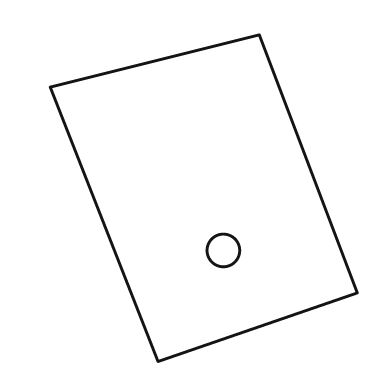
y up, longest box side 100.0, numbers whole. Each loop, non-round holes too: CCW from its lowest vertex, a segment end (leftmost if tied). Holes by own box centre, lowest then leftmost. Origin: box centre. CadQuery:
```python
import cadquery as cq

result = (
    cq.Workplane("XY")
    .moveTo(-14.0, -50.0)
    .lineTo(47.0, -29.0)
    .lineTo(17.0, 50.0)
    .lineTo(-47.0, 34.0)
    .close()
    .moveTo(6.0, -16.0)
    .circle(5.0)
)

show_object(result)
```